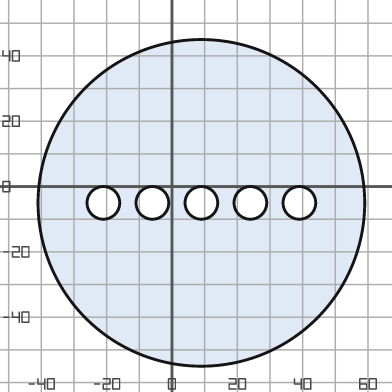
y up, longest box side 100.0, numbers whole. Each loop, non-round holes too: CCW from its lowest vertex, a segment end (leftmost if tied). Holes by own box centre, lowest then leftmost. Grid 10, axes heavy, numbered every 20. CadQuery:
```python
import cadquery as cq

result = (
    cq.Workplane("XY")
    .moveTo(9.0, -5.0)
    .circle(50.0)
    .moveTo(-21.0, -5.0)
    .circle(5.0)
    .moveTo(-6.0, -5.0)
    .circle(5.0)
    .moveTo(9.0, -5.0)
    .circle(5.0)
    .moveTo(24.0, -5.0)
    .circle(5.0)
    .moveTo(39.0, -5.0)
    .circle(5.0)
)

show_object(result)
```